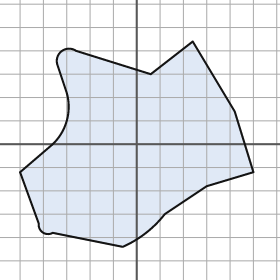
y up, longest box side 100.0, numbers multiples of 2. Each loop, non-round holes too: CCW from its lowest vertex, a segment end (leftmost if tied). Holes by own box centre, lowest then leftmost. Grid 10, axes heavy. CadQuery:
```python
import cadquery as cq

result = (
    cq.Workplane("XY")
    .moveTo(-6.0, -44.0)
    .threePointArc((4.0, -38.0), (12.0, -30.0))
    .lineTo(30.0, -18.0)
    .lineTo(50.0, -12.0)
    .lineTo(42.0, 14.0)
    .lineTo(24.0, 44.0)
    .lineTo(6.0, 30.0)
    .lineTo(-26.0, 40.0)
    .threePointArc((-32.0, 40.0), (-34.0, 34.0))
    .lineTo(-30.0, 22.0)
    .threePointArc((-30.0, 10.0), (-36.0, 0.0))
    .lineTo(-50.0, -12.0)
    .lineTo(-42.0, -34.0)
    .threePointArc((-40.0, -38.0), (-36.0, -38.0))
    .close()
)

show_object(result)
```